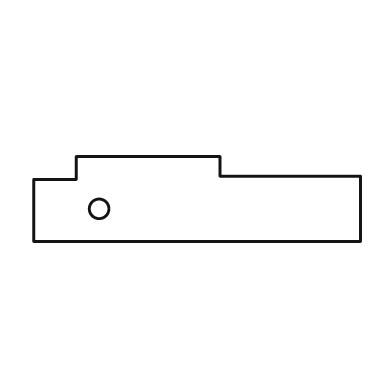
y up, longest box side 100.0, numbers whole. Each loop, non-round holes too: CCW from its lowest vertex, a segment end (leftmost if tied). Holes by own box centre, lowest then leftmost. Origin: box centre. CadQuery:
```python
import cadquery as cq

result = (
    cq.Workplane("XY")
    .moveTo(-50.0, -13.0)
    .lineTo(50.0, -13.0)
    .lineTo(50.0, 7.0)
    .lineTo(7.0, 7.0)
    .lineTo(7.0, 13.0)
    .lineTo(-37.0, 13.0)
    .lineTo(-37.0, 6.0)
    .lineTo(-50.0, 6.0)
    .close()
    .moveTo(-30.0, -3.0)
    .circle(3.0)
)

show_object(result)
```